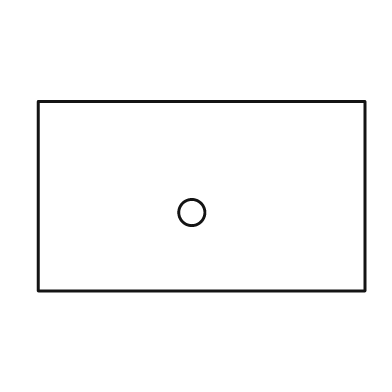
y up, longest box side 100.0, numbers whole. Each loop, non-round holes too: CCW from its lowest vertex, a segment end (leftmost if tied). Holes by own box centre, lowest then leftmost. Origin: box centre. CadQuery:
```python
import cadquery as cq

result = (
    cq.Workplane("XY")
    .moveTo(-50.0, -29.0)
    .lineTo(50.0, -29.0)
    .lineTo(50.0, 29.0)
    .lineTo(-50.0, 29.0)
    .close()
    .moveTo(-3.0, -5.0)
    .circle(4.0)
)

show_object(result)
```